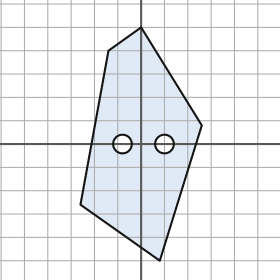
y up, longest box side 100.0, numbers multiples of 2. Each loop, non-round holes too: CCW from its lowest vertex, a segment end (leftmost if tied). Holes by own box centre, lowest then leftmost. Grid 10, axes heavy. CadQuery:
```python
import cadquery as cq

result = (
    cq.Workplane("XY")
    .moveTo(8.0, -50.0)
    .lineTo(26.0, 8.0)
    .lineTo(0.0, 50.0)
    .lineTo(-14.0, 40.0)
    .lineTo(-26.0, -26.0)
    .close()
    .moveTo(-8.0, 0.0)
    .circle(4.0)
    .moveTo(10.0, 0.0)
    .circle(4.0)
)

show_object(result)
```